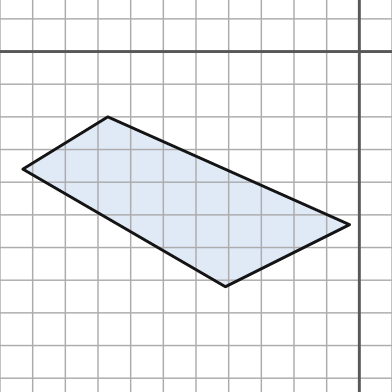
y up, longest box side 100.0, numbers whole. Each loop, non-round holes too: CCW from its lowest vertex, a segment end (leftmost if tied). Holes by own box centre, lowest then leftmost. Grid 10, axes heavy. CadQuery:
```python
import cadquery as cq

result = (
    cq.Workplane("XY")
    .moveTo(-41.0, -72.0)
    .lineTo(-3.0, -53.0)
    .lineTo(-77.0, -20.0)
    .lineTo(-103.0, -36.0)
    .close()
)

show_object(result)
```